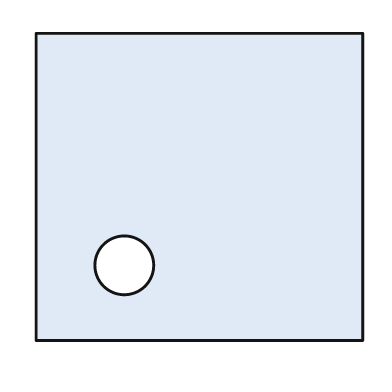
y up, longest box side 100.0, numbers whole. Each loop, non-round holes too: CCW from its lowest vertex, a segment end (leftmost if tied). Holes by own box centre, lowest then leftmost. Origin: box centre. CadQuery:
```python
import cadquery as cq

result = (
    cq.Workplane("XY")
    .moveTo(-50.0, -47.0)
    .lineTo(50.0, -47.0)
    .lineTo(50.0, 47.0)
    .lineTo(-50.0, 47.0)
    .close()
    .moveTo(-23.0, -24.0)
    .circle(9.0)
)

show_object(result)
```